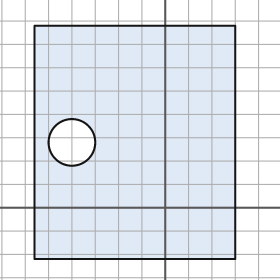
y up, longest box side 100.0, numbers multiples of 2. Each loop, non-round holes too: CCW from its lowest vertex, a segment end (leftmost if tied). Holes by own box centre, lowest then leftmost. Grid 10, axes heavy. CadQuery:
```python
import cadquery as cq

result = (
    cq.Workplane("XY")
    .moveTo(-56.0, -22.0)
    .lineTo(30.0, -22.0)
    .lineTo(30.0, 78.0)
    .lineTo(-56.0, 78.0)
    .close()
    .moveTo(-40.0, 28.0)
    .circle(10.0)
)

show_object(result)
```